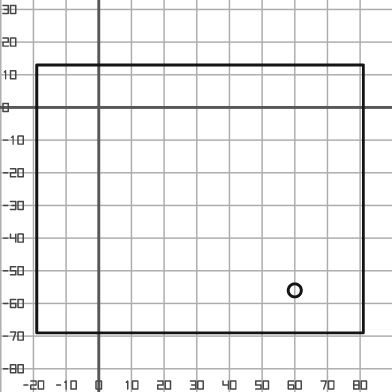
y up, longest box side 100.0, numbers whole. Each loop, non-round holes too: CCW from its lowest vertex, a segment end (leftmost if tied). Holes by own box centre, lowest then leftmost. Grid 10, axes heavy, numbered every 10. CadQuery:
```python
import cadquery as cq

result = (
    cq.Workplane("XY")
    .moveTo(-19.0, -69.0)
    .lineTo(81.0, -69.0)
    .lineTo(81.0, 13.0)
    .lineTo(-19.0, 13.0)
    .close()
    .moveTo(60.0, -56.0)
    .circle(2.0)
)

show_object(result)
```